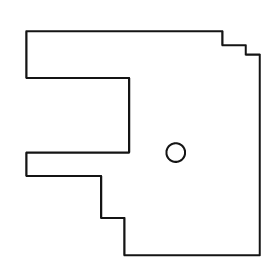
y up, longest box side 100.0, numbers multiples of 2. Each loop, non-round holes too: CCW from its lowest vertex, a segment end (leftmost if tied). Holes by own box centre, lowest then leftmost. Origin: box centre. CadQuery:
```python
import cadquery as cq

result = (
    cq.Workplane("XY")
    .moveTo(-8.0, -48.0)
    .lineTo(50.0, -48.0)
    .lineTo(50.0, 38.0)
    .lineTo(44.0, 38.0)
    .lineTo(44.0, 42.0)
    .lineTo(34.0, 42.0)
    .lineTo(34.0, 48.0)
    .lineTo(-50.0, 48.0)
    .lineTo(-50.0, 28.0)
    .lineTo(-6.0, 28.0)
    .lineTo(-6.0, -4.0)
    .lineTo(-50.0, -4.0)
    .lineTo(-50.0, -14.0)
    .lineTo(-18.0, -14.0)
    .lineTo(-18.0, -32.0)
    .lineTo(-8.0, -32.0)
    .close()
    .moveTo(14.0, -4.0)
    .circle(4.0)
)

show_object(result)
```